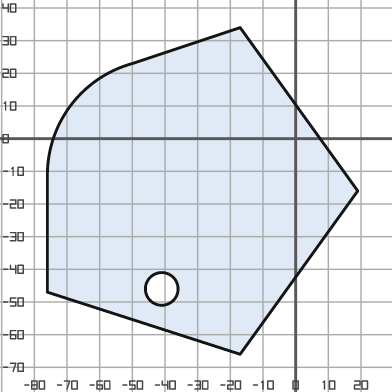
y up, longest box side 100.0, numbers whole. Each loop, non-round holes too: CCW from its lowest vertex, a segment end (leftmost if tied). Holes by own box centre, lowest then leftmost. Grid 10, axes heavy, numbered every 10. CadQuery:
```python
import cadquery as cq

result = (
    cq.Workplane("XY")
    .moveTo(-17.0, -66.0)
    .lineTo(19.0, -16.0)
    .lineTo(-17.0, 34.0)
    .lineTo(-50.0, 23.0)
    .threePointArc((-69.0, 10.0), (-76.0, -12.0))
    .lineTo(-76.0, -47.0)
    .close()
    .moveTo(-41.0, -46.0)
    .circle(5.0)
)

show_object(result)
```